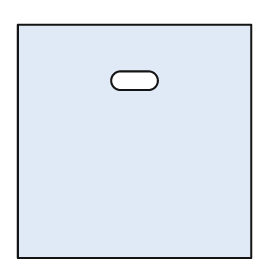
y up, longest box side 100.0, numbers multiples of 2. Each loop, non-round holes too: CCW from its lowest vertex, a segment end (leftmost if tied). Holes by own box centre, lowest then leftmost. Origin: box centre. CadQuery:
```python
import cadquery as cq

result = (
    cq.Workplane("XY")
    .moveTo(-50.0, -50.0)
    .lineTo(50.0, -50.0)
    .lineTo(50.0, 50.0)
    .lineTo(-50.0, 50.0)
    .close()
    .moveTo(-6.0, 22.0)
    .lineTo(6.0, 22.0)
    .threePointArc((10.0, 26.0), (6.0, 30.0))
    .lineTo(-6.0, 30.0)
    .threePointArc((-10.0, 26.0), (-6.0, 22.0))
    .close()
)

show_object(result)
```